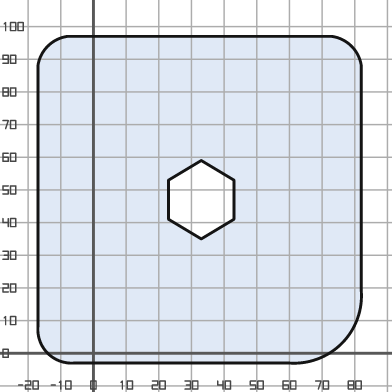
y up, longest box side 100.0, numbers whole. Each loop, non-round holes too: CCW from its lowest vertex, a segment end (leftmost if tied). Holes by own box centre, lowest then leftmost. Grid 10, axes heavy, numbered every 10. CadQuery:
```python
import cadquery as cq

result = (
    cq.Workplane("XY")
    .moveTo(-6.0, -3.0)
    .lineTo(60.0, -3.0)
    .threePointArc((76.0, 3.0), (82.0, 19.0))
    .lineTo(82.0, 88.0)
    .threePointArc((79.0, 94.0), (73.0, 97.0))
    .lineTo(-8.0, 97.0)
    .threePointArc((-14.0, 94.0), (-17.0, 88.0))
    .lineTo(-17.0, 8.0)
    .threePointArc((-14.0, 0.0), (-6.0, -3.0))
    .close()
    .moveTo(33.0, 35.0)
    .lineTo(43.0, 41.0)
    .lineTo(43.0, 53.0)
    .lineTo(33.0, 59.0)
    .lineTo(23.0, 53.0)
    .lineTo(23.0, 41.0)
    .close()
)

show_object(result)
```